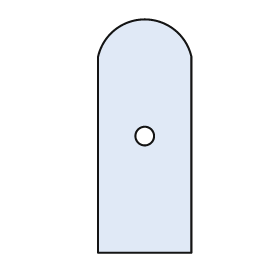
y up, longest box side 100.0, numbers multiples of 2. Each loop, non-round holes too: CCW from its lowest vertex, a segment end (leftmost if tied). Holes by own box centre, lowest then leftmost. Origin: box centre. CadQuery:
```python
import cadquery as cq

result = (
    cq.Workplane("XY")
    .moveTo(-20.0, -50.0)
    .lineTo(20.0, -50.0)
    .lineTo(20.0, 34.0)
    .threePointArc((0.0, 50.0), (-20.0, 34.0))
    .close()
    .moveTo(0.0, 0.0)
    .circle(4.0)
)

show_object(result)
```